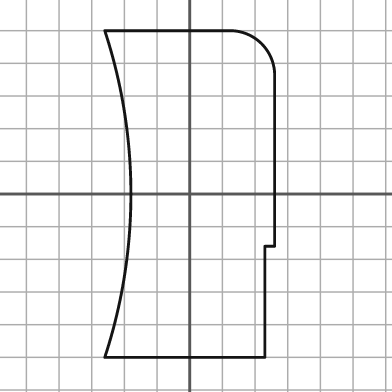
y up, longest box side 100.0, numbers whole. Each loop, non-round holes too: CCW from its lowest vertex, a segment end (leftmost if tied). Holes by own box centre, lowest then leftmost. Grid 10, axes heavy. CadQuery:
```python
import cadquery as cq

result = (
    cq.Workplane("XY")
    .moveTo(-26.0, -50.0)
    .lineTo(23.0, -50.0)
    .lineTo(23.0, -16.0)
    .lineTo(26.0, -16.0)
    .lineTo(26.0, 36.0)
    .threePointArc((22.0, 46.0), (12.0, 50.0))
    .lineTo(-26.0, 50.0)
    .threePointArc((-18.0, 0.0), (-26.0, -50.0))
    .close()
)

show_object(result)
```